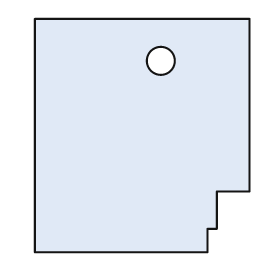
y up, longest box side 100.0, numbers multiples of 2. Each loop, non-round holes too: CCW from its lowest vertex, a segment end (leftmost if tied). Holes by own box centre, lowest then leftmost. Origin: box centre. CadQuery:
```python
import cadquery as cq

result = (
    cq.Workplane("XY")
    .moveTo(-46.0, -50.0)
    .lineTo(28.0, -50.0)
    .lineTo(28.0, -40.0)
    .lineTo(32.0, -40.0)
    .lineTo(32.0, -24.0)
    .lineTo(46.0, -24.0)
    .lineTo(46.0, 50.0)
    .lineTo(-46.0, 50.0)
    .close()
    .moveTo(8.0, 32.0)
    .circle(6.0)
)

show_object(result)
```